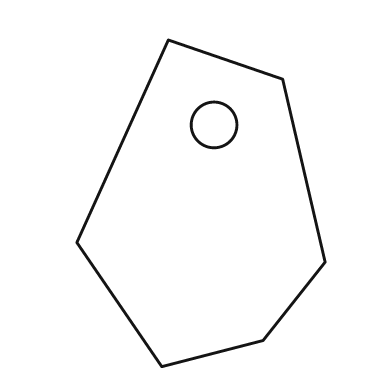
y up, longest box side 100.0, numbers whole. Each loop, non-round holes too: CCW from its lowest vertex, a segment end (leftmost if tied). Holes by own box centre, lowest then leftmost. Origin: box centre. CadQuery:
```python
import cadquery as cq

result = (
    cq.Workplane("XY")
    .moveTo(-12.0, -50.0)
    .lineTo(19.0, -42.0)
    .lineTo(38.0, -18.0)
    .lineTo(25.0, 38.0)
    .lineTo(-10.0, 50.0)
    .lineTo(-38.0, -12.0)
    .close()
    .moveTo(4.0, 24.0)
    .circle(7.0)
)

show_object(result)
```